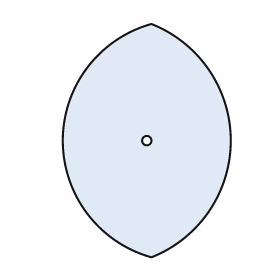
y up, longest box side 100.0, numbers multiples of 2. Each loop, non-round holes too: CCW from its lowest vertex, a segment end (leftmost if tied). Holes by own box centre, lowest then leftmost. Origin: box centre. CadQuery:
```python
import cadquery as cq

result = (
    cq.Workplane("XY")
    .moveTo(2.0, -50.0)
    .threePointArc((36.0, 0.0), (2.0, 50.0))
    .threePointArc((-36.0, 0.0), (2.0, -50.0))
    .close()
    .moveTo(0.0, 0.0)
    .circle(2.0)
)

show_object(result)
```